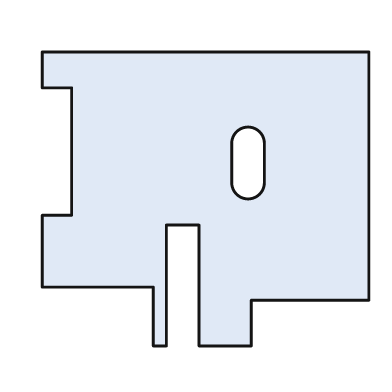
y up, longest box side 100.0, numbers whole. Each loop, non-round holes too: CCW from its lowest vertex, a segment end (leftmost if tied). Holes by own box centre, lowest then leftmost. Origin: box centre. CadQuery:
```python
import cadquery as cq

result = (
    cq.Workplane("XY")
    .moveTo(-16.0, -45.0)
    .lineTo(-12.0, -45.0)
    .lineTo(-12.0, -8.0)
    .lineTo(-2.0, -8.0)
    .lineTo(-2.0, -45.0)
    .lineTo(14.0, -45.0)
    .lineTo(14.0, -31.0)
    .lineTo(50.0, -31.0)
    .lineTo(50.0, 45.0)
    .lineTo(-50.0, 45.0)
    .lineTo(-50.0, 34.0)
    .lineTo(-41.0, 34.0)
    .lineTo(-41.0, -5.0)
    .lineTo(-50.0, -5.0)
    .lineTo(-50.0, -27.0)
    .lineTo(-16.0, -27.0)
    .close()
    .moveTo(8.0, 5.0)
    .threePointArc((13.0, 0.0), (18.0, 5.0))
    .lineTo(18.0, 17.0)
    .threePointArc((13.0, 22.0), (8.0, 17.0))
    .close()
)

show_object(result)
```